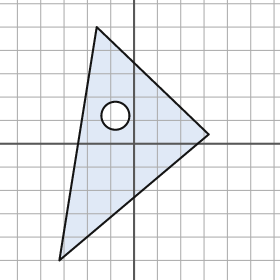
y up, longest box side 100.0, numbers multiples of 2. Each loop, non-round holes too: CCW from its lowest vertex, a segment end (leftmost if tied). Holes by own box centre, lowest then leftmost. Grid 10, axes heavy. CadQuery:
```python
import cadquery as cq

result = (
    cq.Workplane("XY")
    .moveTo(-32.0, -50.0)
    .lineTo(32.0, 4.0)
    .lineTo(-16.0, 50.0)
    .close()
    .moveTo(-8.0, 12.0)
    .circle(6.0)
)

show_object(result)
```